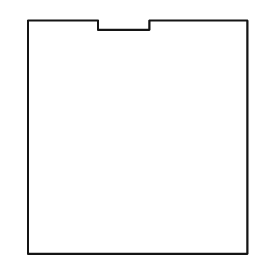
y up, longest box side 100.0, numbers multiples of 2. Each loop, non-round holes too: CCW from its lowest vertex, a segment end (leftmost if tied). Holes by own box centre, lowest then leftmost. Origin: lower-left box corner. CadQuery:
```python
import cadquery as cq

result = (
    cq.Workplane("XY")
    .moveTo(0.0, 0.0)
    .lineTo(94.0, 0.0)
    .lineTo(94.0, 100.0)
    .lineTo(52.0, 100.0)
    .lineTo(52.0, 96.0)
    .lineTo(30.0, 96.0)
    .lineTo(30.0, 100.0)
    .lineTo(0.0, 100.0)
    .close()
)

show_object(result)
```